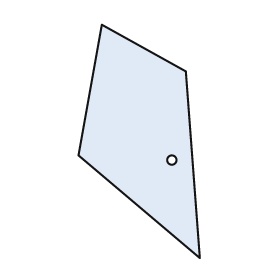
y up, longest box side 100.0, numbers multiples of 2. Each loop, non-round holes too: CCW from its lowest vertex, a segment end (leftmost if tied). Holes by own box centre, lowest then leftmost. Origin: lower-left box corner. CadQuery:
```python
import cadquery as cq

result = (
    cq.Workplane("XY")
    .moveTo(52.0, 0.0)
    .lineTo(46.0, 80.0)
    .lineTo(10.0, 100.0)
    .lineTo(0.0, 44.0)
    .close()
    .moveTo(40.0, 42.0)
    .circle(2.0)
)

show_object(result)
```